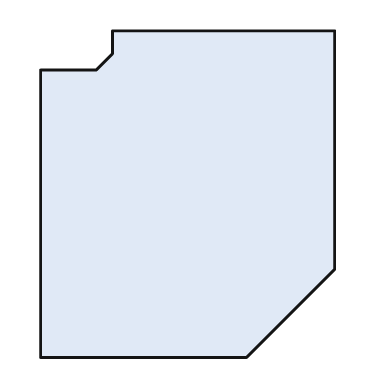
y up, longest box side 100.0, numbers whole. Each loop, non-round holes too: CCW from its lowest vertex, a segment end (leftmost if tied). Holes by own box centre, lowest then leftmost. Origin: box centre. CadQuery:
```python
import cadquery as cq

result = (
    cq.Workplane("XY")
    .moveTo(-45.0, -50.0)
    .lineTo(18.0, -50.0)
    .lineTo(45.0, -23.0)
    .lineTo(45.0, 50.0)
    .lineTo(-23.0, 50.0)
    .lineTo(-23.0, 43.0)
    .lineTo(-28.0, 38.0)
    .lineTo(-45.0, 38.0)
    .close()
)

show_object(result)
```